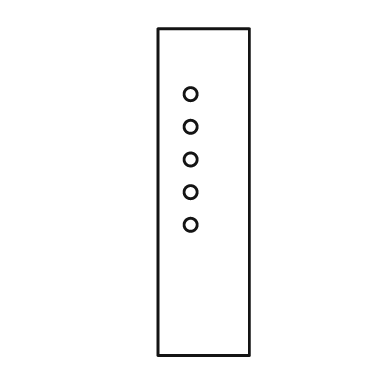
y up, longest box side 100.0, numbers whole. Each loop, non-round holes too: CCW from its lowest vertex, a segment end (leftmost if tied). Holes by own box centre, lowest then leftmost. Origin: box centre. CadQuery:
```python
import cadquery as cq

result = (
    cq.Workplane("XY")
    .moveTo(-14.0, -50.0)
    .lineTo(14.0, -50.0)
    .lineTo(14.0, 50.0)
    .lineTo(-14.0, 50.0)
    .close()
    .moveTo(-4.0, -10.0)
    .circle(2.0)
    .moveTo(-4.0, 0.0)
    .circle(2.0)
    .moveTo(-4.0, 10.0)
    .circle(2.0)
    .moveTo(-4.0, 20.0)
    .circle(2.0)
    .moveTo(-4.0, 30.0)
    .circle(2.0)
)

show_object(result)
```